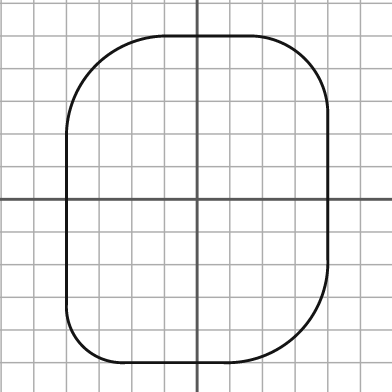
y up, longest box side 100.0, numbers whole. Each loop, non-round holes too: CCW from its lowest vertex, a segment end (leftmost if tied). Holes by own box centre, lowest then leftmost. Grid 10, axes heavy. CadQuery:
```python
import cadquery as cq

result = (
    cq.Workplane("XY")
    .moveTo(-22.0, -50.0)
    .lineTo(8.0, -50.0)
    .threePointArc((31.0, -41.0), (40.0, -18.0))
    .lineTo(40.0, 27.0)
    .threePointArc((33.0, 43.0), (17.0, 50.0))
    .lineTo(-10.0, 50.0)
    .threePointArc((-31.0, 41.0), (-40.0, 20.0))
    .lineTo(-40.0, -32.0)
    .threePointArc((-35.0, -45.0), (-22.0, -50.0))
    .close()
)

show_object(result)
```